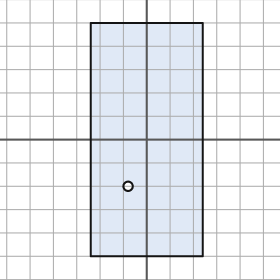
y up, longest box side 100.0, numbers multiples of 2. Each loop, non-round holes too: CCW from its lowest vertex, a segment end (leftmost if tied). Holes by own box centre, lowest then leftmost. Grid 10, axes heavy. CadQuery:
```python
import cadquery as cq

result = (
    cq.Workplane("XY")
    .moveTo(-24.0, -50.0)
    .lineTo(24.0, -50.0)
    .lineTo(24.0, 50.0)
    .lineTo(-24.0, 50.0)
    .close()
    .moveTo(-8.0, -20.0)
    .circle(2.0)
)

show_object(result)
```